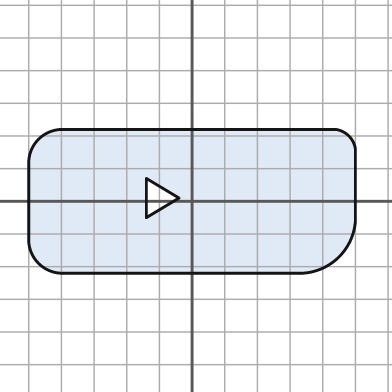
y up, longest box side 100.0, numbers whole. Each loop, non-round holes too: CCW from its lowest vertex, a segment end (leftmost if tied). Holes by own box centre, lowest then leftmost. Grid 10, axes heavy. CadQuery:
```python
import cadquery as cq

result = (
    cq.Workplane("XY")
    .moveTo(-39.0, -22.0)
    .lineTo(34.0, -22.0)
    .threePointArc((45.0, -17.0), (50.0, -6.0))
    .lineTo(50.0, 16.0)
    .threePointArc((48.0, 20.0), (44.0, 22.0))
    .lineTo(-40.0, 22.0)
    .threePointArc((-47.0, 19.0), (-50.0, 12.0))
    .lineTo(-50.0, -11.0)
    .threePointArc((-47.0, -19.0), (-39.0, -22.0))
    .close()
    .moveTo(-14.0, -5.0)
    .lineTo(-4.0, 1.0)
    .lineTo(-14.0, 7.0)
    .close()
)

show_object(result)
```